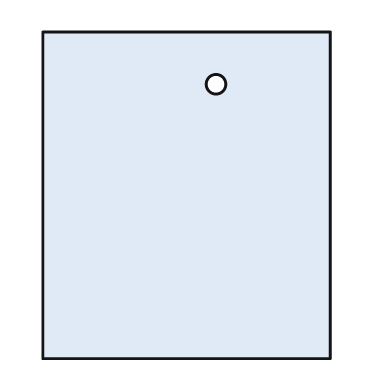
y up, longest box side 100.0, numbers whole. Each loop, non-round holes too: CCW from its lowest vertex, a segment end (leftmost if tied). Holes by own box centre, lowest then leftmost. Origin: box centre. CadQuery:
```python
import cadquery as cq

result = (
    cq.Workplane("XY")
    .moveTo(-44.0, -50.0)
    .lineTo(44.0, -50.0)
    .lineTo(44.0, 50.0)
    .lineTo(-44.0, 50.0)
    .close()
    .moveTo(9.0, 34.0)
    .circle(3.0)
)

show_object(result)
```